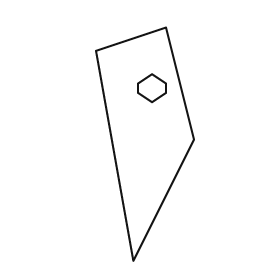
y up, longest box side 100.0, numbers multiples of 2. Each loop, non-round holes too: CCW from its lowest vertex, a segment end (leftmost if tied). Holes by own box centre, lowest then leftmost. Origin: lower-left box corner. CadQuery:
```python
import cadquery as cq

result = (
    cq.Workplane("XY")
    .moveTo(16.0, 0.0)
    .lineTo(42.0, 52.0)
    .lineTo(30.0, 100.0)
    .lineTo(0.0, 90.0)
    .close()
    .moveTo(24.0, 68.0)
    .lineTo(30.0, 72.0)
    .lineTo(30.0, 76.0)
    .lineTo(24.0, 80.0)
    .lineTo(18.0, 76.0)
    .lineTo(18.0, 72.0)
    .close()
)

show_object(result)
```